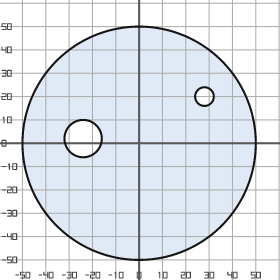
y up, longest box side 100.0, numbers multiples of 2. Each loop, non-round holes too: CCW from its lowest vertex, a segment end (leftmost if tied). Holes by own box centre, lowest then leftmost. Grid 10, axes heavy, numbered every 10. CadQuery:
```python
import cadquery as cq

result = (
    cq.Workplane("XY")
    .moveTo(0.0, 0.0)
    .circle(50.0)
    .moveTo(-24.0, 2.0)
    .circle(8.0)
    .moveTo(28.0, 20.0)
    .circle(4.0)
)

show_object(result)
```